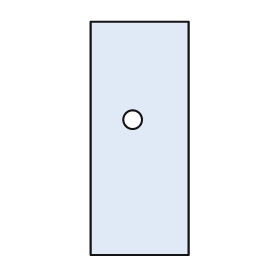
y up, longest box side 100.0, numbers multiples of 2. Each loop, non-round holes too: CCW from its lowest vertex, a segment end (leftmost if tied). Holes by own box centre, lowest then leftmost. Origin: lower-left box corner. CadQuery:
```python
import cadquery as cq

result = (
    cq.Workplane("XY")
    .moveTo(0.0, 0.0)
    .lineTo(42.0, 0.0)
    .lineTo(42.0, 100.0)
    .lineTo(0.0, 100.0)
    .close()
    .moveTo(18.0, 58.0)
    .circle(4.0)
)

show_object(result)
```